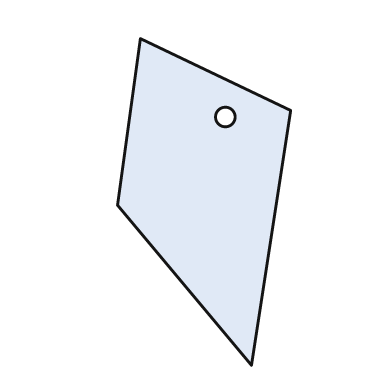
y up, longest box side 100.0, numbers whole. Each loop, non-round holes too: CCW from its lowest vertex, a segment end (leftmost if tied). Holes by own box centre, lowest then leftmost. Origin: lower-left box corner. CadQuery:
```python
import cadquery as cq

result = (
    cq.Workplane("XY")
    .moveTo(41.0, 0.0)
    .lineTo(53.0, 78.0)
    .lineTo(7.0, 100.0)
    .lineTo(0.0, 49.0)
    .close()
    .moveTo(33.0, 76.0)
    .circle(3.0)
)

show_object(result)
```